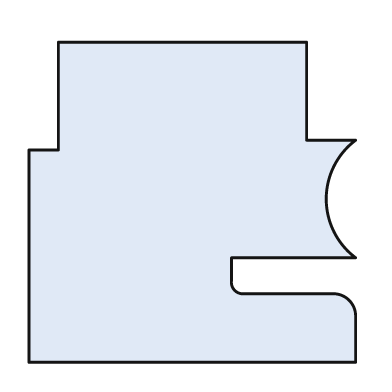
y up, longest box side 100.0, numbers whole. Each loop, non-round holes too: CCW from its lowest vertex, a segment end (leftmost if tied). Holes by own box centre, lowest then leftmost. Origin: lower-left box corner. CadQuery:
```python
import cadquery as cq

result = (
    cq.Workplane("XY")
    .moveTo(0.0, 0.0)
    .lineTo(100.0, 0.0)
    .lineTo(100.0, 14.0)
    .threePointArc((98.0, 19.0), (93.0, 21.0))
    .lineTo(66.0, 21.0)
    .threePointArc((63.0, 22.0), (62.0, 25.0))
    .lineTo(62.0, 32.0)
    .lineTo(100.0, 32.0)
    .threePointArc((91.0, 50.0), (100.0, 68.0))
    .lineTo(85.0, 68.0)
    .lineTo(85.0, 98.0)
    .lineTo(9.0, 98.0)
    .lineTo(9.0, 65.0)
    .lineTo(0.0, 65.0)
    .close()
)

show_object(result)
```